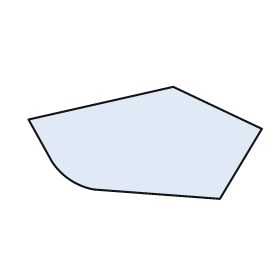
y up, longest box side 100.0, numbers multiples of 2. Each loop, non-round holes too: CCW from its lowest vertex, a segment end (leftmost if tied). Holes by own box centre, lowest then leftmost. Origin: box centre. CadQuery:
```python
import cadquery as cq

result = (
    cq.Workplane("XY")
    .moveTo(32.0, -24.0)
    .lineTo(50.0, 6.0)
    .lineTo(12.0, 24.0)
    .lineTo(-50.0, 10.0)
    .lineTo(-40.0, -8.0)
    .threePointArc((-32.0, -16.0), (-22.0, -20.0))
    .close()
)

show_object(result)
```